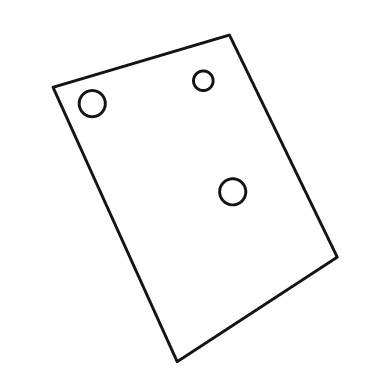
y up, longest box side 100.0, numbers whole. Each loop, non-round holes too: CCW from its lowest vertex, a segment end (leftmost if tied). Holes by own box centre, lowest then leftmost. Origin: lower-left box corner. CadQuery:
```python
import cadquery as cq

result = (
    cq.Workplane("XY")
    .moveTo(38.0, 0.0)
    .lineTo(87.0, 32.0)
    .lineTo(54.0, 100.0)
    .lineTo(0.0, 84.0)
    .close()
    .moveTo(55.0, 52.0)
    .circle(4.0)
    .moveTo(12.0, 79.0)
    .circle(4.0)
    .moveTo(46.0, 86.0)
    .circle(3.0)
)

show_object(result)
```